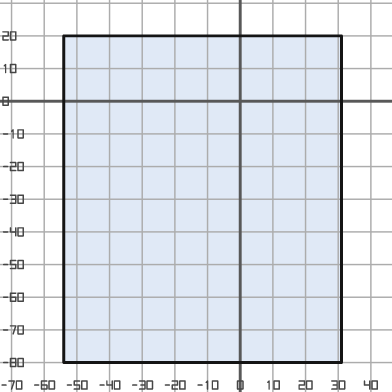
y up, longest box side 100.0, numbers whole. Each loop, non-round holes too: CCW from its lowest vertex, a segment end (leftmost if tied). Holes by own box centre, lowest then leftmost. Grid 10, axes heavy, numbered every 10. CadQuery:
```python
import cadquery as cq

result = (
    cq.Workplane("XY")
    .moveTo(-54.0, -80.0)
    .lineTo(31.0, -80.0)
    .lineTo(31.0, 20.0)
    .lineTo(-54.0, 20.0)
    .close()
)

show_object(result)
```